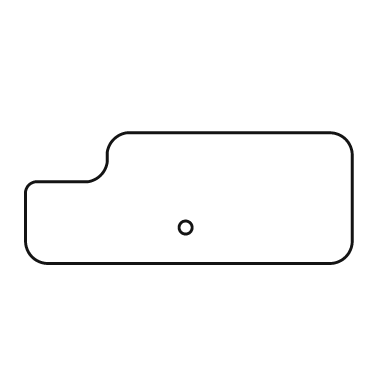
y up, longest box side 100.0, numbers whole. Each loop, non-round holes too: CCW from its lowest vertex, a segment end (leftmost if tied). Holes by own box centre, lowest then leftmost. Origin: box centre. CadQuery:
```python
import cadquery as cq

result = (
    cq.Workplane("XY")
    .moveTo(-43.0, -20.0)
    .lineTo(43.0, -20.0)
    .threePointArc((48.0, -18.0), (50.0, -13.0))
    .lineTo(50.0, 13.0)
    .threePointArc((48.0, 18.0), (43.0, 20.0))
    .lineTo(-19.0, 20.0)
    .threePointArc((-23.0, 18.0), (-25.0, 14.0))
    .lineTo(-25.0, 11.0)
    .threePointArc((-27.0, 7.0), (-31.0, 5.0))
    .lineTo(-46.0, 5.0)
    .threePointArc((-49.0, 4.0), (-50.0, 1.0))
    .lineTo(-50.0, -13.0)
    .threePointArc((-48.0, -18.0), (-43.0, -20.0))
    .close()
    .moveTo(-1.0, -9.0)
    .circle(2.0)
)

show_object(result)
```